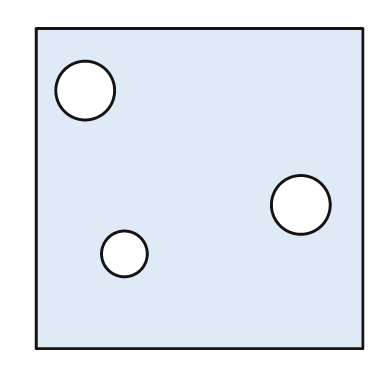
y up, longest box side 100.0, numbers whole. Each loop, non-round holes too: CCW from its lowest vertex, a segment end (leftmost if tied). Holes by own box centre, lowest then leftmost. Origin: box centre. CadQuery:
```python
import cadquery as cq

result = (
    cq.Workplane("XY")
    .moveTo(-50.0, -49.0)
    .lineTo(50.0, -49.0)
    .lineTo(50.0, 49.0)
    .lineTo(-50.0, 49.0)
    .close()
    .moveTo(-23.0, -20.0)
    .circle(7.0)
    .moveTo(31.0, -5.0)
    .circle(9.0)
    .moveTo(-35.0, 30.0)
    .circle(9.0)
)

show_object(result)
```